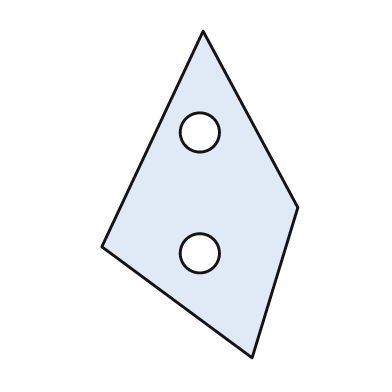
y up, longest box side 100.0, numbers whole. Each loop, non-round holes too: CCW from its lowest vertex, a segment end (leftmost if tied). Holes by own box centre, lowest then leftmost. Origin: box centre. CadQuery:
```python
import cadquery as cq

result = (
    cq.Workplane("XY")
    .moveTo(16.0, -50.0)
    .lineTo(30.0, -4.0)
    .lineTo(1.0, 50.0)
    .lineTo(-30.0, -16.0)
    .close()
    .moveTo(0.0, -18.0)
    .circle(6.0)
    .moveTo(0.0, 19.0)
    .circle(6.0)
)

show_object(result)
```